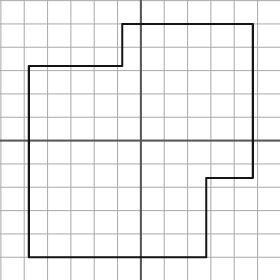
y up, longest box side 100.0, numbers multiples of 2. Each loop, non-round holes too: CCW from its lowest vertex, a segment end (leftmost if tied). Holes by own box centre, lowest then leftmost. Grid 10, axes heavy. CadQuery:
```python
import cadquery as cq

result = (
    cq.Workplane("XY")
    .moveTo(-48.0, -50.0)
    .lineTo(28.0, -50.0)
    .lineTo(28.0, -16.0)
    .lineTo(48.0, -16.0)
    .lineTo(48.0, 50.0)
    .lineTo(-8.0, 50.0)
    .lineTo(-8.0, 32.0)
    .lineTo(-48.0, 32.0)
    .close()
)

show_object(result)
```